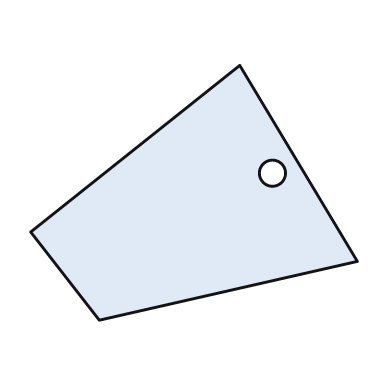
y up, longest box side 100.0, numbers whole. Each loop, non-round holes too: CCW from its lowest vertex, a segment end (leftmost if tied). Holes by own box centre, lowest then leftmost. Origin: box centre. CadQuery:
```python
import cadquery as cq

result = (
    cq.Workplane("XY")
    .moveTo(-29.0, -39.0)
    .lineTo(50.0, -21.0)
    .lineTo(14.0, 39.0)
    .lineTo(-50.0, -12.0)
    .close()
    .moveTo(24.0, 6.0)
    .circle(4.0)
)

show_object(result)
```